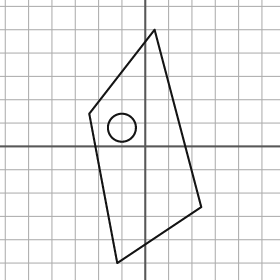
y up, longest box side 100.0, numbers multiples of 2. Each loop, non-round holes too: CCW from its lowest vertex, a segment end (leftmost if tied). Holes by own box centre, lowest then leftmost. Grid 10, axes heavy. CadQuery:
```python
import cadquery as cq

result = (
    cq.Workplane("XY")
    .moveTo(-12.0, -50.0)
    .lineTo(24.0, -26.0)
    .lineTo(4.0, 50.0)
    .lineTo(-24.0, 14.0)
    .close()
    .moveTo(-10.0, 8.0)
    .circle(6.0)
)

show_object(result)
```